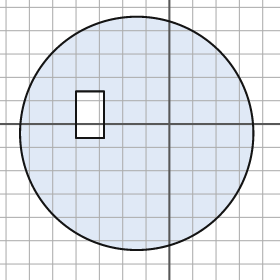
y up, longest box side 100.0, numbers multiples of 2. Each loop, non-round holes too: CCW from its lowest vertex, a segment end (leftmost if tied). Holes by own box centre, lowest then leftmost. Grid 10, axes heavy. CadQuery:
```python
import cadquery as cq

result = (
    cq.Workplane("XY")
    .moveTo(-14.0, -4.0)
    .circle(50.0)
    .moveTo(-40.0, -6.0)
    .lineTo(-28.0, -6.0)
    .lineTo(-28.0, 14.0)
    .lineTo(-40.0, 14.0)
    .close()
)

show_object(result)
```